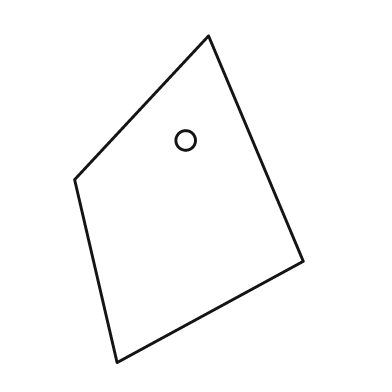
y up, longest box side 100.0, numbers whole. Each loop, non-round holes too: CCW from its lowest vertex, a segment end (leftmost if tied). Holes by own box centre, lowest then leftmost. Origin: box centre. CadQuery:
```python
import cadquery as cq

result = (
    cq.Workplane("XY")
    .moveTo(-22.0, -50.0)
    .lineTo(35.0, -19.0)
    .lineTo(6.0, 50.0)
    .lineTo(-35.0, 6.0)
    .close()
    .moveTo(-1.0, 18.0)
    .circle(3.0)
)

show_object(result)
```